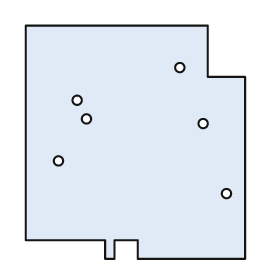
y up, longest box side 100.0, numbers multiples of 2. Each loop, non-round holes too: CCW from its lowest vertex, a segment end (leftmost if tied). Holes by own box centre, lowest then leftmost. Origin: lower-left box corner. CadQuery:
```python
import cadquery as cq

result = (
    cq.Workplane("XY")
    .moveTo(34.0, 0.0)
    .lineTo(38.0, 0.0)
    .lineTo(38.0, 8.0)
    .lineTo(48.0, 8.0)
    .lineTo(48.0, 0.0)
    .lineTo(94.0, 0.0)
    .lineTo(94.0, 78.0)
    .lineTo(78.0, 78.0)
    .lineTo(78.0, 100.0)
    .lineTo(0.0, 100.0)
    .lineTo(0.0, 8.0)
    .lineTo(34.0, 8.0)
    .close()
    .moveTo(86.0, 28.0)
    .circle(2.0)
    .moveTo(14.0, 42.0)
    .circle(2.0)
    .moveTo(76.0, 58.0)
    .circle(2.0)
    .moveTo(26.0, 60.0)
    .circle(2.0)
    .moveTo(22.0, 68.0)
    .circle(2.0)
    .moveTo(66.0, 82.0)
    .circle(2.0)
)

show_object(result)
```